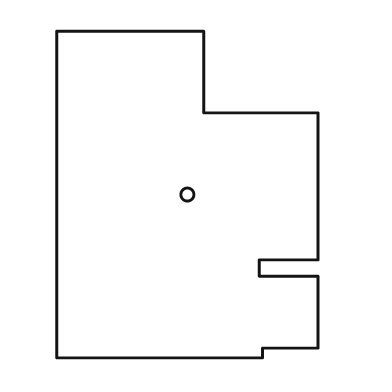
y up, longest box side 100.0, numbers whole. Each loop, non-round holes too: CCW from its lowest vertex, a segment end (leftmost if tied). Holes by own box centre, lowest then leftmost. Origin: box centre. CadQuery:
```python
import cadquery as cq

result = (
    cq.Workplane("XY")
    .moveTo(-40.0, -50.0)
    .lineTo(23.0, -50.0)
    .lineTo(23.0, -47.0)
    .lineTo(40.0, -47.0)
    .lineTo(40.0, -25.0)
    .lineTo(22.0, -25.0)
    .lineTo(22.0, -20.0)
    .lineTo(40.0, -20.0)
    .lineTo(40.0, 25.0)
    .lineTo(5.0, 25.0)
    .lineTo(5.0, 50.0)
    .lineTo(-40.0, 50.0)
    .close()
    .moveTo(0.0, 0.0)
    .circle(2.0)
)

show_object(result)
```